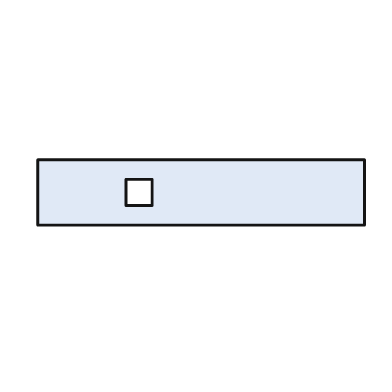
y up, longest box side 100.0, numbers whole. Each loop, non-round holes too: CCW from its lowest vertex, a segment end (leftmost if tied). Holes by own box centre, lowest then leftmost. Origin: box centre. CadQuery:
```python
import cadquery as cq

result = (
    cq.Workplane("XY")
    .moveTo(-50.0, -10.0)
    .lineTo(50.0, -10.0)
    .lineTo(50.0, 10.0)
    .lineTo(-50.0, 10.0)
    .close()
    .moveTo(-23.0, -4.0)
    .lineTo(-15.0, -4.0)
    .lineTo(-15.0, 4.0)
    .lineTo(-23.0, 4.0)
    .close()
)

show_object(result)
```